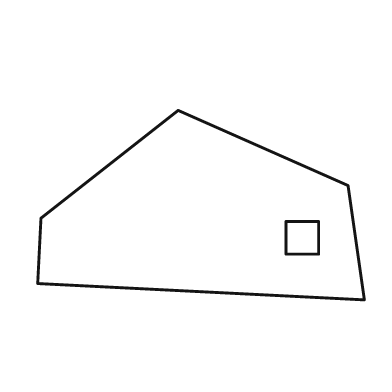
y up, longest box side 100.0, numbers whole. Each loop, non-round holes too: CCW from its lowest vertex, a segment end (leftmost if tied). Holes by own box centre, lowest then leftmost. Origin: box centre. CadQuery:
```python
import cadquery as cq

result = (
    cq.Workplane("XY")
    .moveTo(50.0, -29.0)
    .lineTo(45.0, 6.0)
    .lineTo(-7.0, 29.0)
    .lineTo(-49.0, -4.0)
    .lineTo(-50.0, -24.0)
    .close()
    .moveTo(26.0, -15.0)
    .lineTo(36.0, -15.0)
    .lineTo(36.0, -5.0)
    .lineTo(26.0, -5.0)
    .close()
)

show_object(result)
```